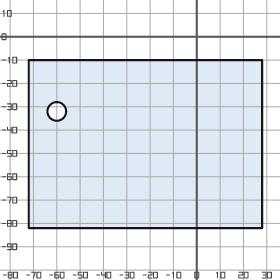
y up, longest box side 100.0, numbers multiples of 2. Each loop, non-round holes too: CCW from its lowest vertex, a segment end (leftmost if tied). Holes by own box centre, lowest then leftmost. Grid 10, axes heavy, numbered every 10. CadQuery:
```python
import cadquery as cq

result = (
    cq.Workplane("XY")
    .moveTo(-72.0, -82.0)
    .lineTo(28.0, -82.0)
    .lineTo(28.0, -10.0)
    .lineTo(-72.0, -10.0)
    .close()
    .moveTo(-60.0, -32.0)
    .circle(4.0)
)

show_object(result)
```